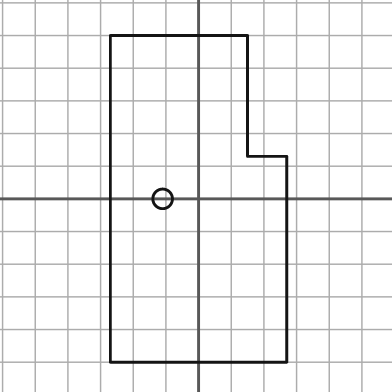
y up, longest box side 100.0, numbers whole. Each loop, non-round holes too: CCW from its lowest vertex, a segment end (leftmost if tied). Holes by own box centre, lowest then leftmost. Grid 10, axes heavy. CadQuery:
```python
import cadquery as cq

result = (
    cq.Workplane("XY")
    .moveTo(-27.0, -50.0)
    .lineTo(27.0, -50.0)
    .lineTo(27.0, 13.0)
    .lineTo(15.0, 13.0)
    .lineTo(15.0, 50.0)
    .lineTo(-27.0, 50.0)
    .close()
    .moveTo(-11.0, 0.0)
    .circle(3.0)
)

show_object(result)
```